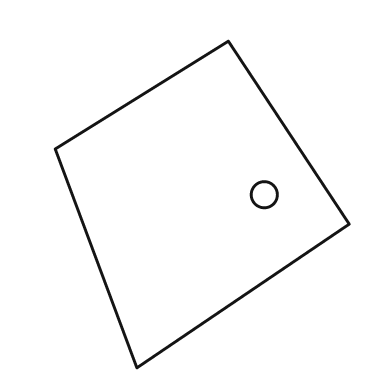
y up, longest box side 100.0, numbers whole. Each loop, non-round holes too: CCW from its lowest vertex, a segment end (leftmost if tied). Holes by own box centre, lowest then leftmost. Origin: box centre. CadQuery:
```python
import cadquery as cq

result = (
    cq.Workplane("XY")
    .moveTo(-20.0, -50.0)
    .lineTo(45.0, -6.0)
    .lineTo(8.0, 50.0)
    .lineTo(-45.0, 17.0)
    .close()
    .moveTo(19.0, 3.0)
    .circle(4.0)
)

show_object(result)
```